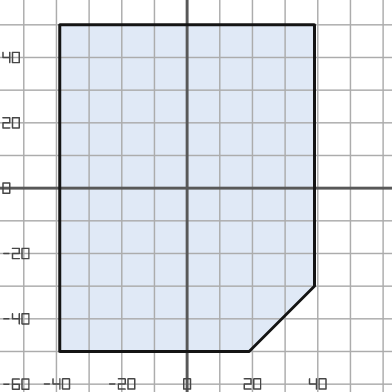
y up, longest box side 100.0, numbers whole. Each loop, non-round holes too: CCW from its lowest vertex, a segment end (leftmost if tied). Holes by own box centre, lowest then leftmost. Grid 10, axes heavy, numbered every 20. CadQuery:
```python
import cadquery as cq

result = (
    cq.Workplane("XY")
    .moveTo(-39.0, -50.0)
    .lineTo(19.0, -50.0)
    .lineTo(39.0, -30.0)
    .lineTo(39.0, 50.0)
    .lineTo(-39.0, 50.0)
    .close()
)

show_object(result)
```